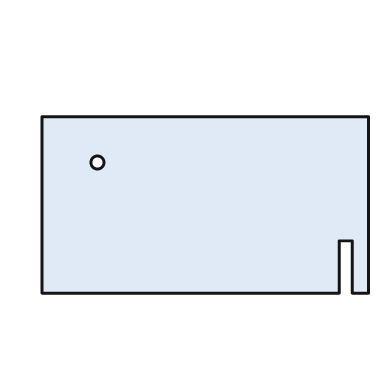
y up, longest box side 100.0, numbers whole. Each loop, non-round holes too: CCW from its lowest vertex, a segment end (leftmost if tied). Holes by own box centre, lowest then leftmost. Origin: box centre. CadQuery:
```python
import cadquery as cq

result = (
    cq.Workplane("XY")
    .moveTo(-50.0, -27.0)
    .lineTo(41.0, -27.0)
    .lineTo(41.0, -11.0)
    .lineTo(45.0, -11.0)
    .lineTo(45.0, -27.0)
    .lineTo(50.0, -27.0)
    .lineTo(50.0, 27.0)
    .lineTo(-50.0, 27.0)
    .close()
    .moveTo(-33.0, 13.0)
    .circle(2.0)
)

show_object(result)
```